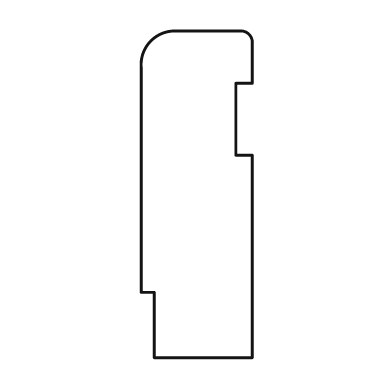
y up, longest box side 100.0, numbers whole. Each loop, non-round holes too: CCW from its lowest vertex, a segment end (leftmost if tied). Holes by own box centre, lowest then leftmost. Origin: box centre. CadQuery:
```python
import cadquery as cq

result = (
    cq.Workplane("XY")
    .moveTo(-13.0, -50.0)
    .lineTo(17.0, -50.0)
    .lineTo(17.0, 12.0)
    .lineTo(12.0, 12.0)
    .lineTo(12.0, 34.0)
    .lineTo(17.0, 34.0)
    .lineTo(17.0, 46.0)
    .threePointArc((16.0, 49.0), (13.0, 50.0))
    .lineTo(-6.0, 50.0)
    .threePointArc((-14.0, 47.0), (-17.0, 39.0))
    .lineTo(-17.0, -30.0)
    .lineTo(-13.0, -30.0)
    .close()
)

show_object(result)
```